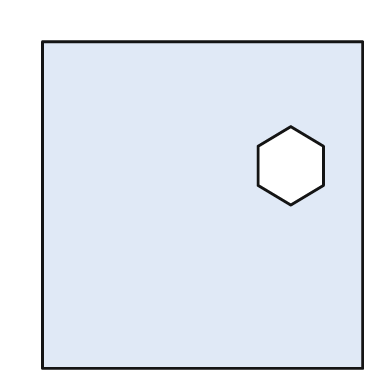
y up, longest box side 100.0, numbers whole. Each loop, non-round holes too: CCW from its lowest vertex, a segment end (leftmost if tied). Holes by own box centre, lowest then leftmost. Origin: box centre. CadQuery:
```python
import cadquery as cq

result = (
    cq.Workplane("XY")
    .moveTo(-49.0, -50.0)
    .lineTo(49.0, -50.0)
    .lineTo(49.0, 50.0)
    .lineTo(-49.0, 50.0)
    .close()
    .moveTo(27.0, 0.0)
    .lineTo(37.0, 6.0)
    .lineTo(37.0, 18.0)
    .lineTo(27.0, 24.0)
    .lineTo(17.0, 18.0)
    .lineTo(17.0, 6.0)
    .close()
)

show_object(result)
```